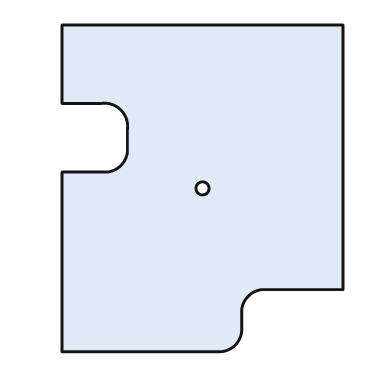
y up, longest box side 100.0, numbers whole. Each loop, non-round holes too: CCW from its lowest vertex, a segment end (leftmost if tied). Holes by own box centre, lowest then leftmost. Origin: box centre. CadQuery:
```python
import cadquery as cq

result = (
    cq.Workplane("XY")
    .moveTo(-43.0, -50.0)
    .lineTo(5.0, -50.0)
    .threePointArc((10.0, -48.0), (12.0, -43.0))
    .lineTo(12.0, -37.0)
    .threePointArc((14.0, -33.0), (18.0, -31.0))
    .lineTo(43.0, -31.0)
    .lineTo(43.0, 50.0)
    .lineTo(-43.0, 50.0)
    .lineTo(-43.0, 26.0)
    .lineTo(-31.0, 26.0)
    .threePointArc((-25.0, 24.0), (-23.0, 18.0))
    .lineTo(-23.0, 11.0)
    .threePointArc((-25.0, 7.0), (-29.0, 5.0))
    .lineTo(-43.0, 5.0)
    .close()
    .moveTo(0.0, 0.0)
    .circle(2.0)
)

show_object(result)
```